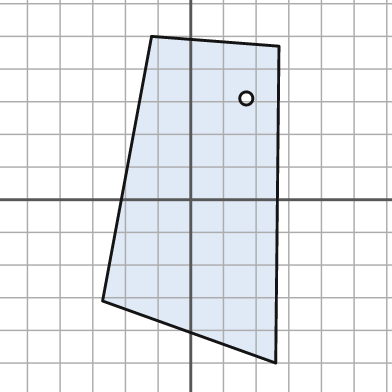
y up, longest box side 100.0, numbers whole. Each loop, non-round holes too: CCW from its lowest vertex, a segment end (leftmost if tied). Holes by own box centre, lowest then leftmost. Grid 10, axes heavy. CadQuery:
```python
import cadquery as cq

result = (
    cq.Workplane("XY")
    .moveTo(26.0, -50.0)
    .lineTo(27.0, 47.0)
    .lineTo(-12.0, 50.0)
    .lineTo(-27.0, -31.0)
    .close()
    .moveTo(17.0, 31.0)
    .circle(2.0)
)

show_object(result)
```